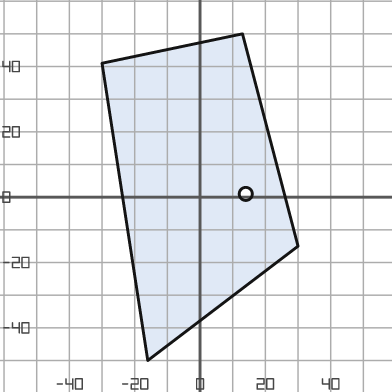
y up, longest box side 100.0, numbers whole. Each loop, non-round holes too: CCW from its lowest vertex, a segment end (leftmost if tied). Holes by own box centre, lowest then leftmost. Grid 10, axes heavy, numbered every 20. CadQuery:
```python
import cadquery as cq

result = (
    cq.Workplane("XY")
    .moveTo(-16.0, -50.0)
    .lineTo(30.0, -15.0)
    .lineTo(13.0, 50.0)
    .lineTo(-30.0, 41.0)
    .close()
    .moveTo(14.0, 1.0)
    .circle(2.0)
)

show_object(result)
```